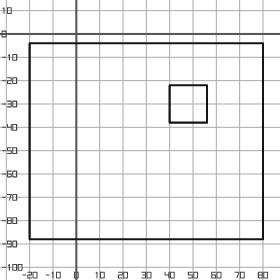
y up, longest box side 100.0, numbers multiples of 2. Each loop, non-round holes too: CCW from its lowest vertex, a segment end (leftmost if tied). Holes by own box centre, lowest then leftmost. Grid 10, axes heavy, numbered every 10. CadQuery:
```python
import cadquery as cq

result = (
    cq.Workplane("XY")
    .moveTo(-20.0, -88.0)
    .lineTo(80.0, -88.0)
    .lineTo(80.0, -4.0)
    .lineTo(-20.0, -4.0)
    .close()
    .moveTo(40.0, -38.0)
    .lineTo(56.0, -38.0)
    .lineTo(56.0, -22.0)
    .lineTo(40.0, -22.0)
    .close()
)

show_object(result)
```